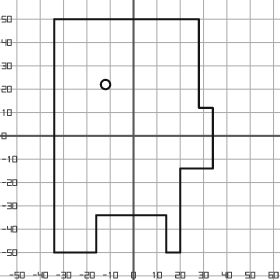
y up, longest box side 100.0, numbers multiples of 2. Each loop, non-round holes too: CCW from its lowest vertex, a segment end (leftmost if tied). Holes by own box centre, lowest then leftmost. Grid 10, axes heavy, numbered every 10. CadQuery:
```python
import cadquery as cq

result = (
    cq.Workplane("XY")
    .moveTo(-34.0, -50.0)
    .lineTo(-16.0, -50.0)
    .lineTo(-16.0, -34.0)
    .lineTo(14.0, -34.0)
    .lineTo(14.0, -50.0)
    .lineTo(20.0, -50.0)
    .lineTo(20.0, -14.0)
    .lineTo(34.0, -14.0)
    .lineTo(34.0, 12.0)
    .lineTo(28.0, 12.0)
    .lineTo(28.0, 50.0)
    .lineTo(-34.0, 50.0)
    .close()
    .moveTo(-12.0, 22.0)
    .circle(2.0)
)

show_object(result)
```